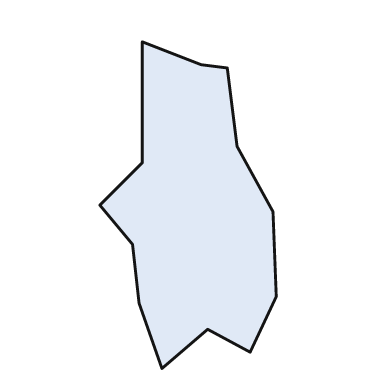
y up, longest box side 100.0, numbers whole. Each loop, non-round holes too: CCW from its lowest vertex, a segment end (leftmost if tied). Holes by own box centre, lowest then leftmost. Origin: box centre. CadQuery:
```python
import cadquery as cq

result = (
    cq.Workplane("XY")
    .moveTo(-8.0, -50.0)
    .lineTo(6.0, -38.0)
    .lineTo(19.0, -45.0)
    .lineTo(27.0, -28.0)
    .lineTo(26.0, -2.0)
    .lineTo(15.0, 18.0)
    .lineTo(12.0, 42.0)
    .lineTo(4.0, 43.0)
    .lineTo(-14.0, 50.0)
    .lineTo(-14.0, 13.0)
    .lineTo(-27.0, 0.0)
    .lineTo(-17.0, -12.0)
    .lineTo(-15.0, -30.0)
    .close()
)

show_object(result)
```